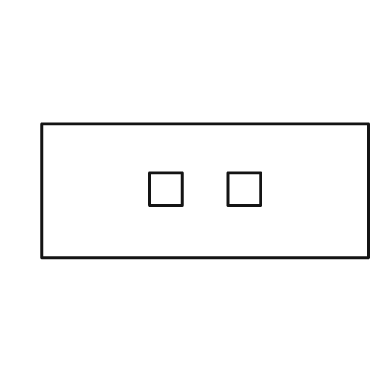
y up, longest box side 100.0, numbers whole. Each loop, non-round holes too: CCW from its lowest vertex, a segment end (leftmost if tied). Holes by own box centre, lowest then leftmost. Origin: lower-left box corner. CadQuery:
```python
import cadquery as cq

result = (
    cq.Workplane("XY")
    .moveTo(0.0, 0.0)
    .lineTo(100.0, 0.0)
    .lineTo(100.0, 41.0)
    .lineTo(0.0, 41.0)
    .close()
    .moveTo(33.0, 16.0)
    .lineTo(43.0, 16.0)
    .lineTo(43.0, 26.0)
    .lineTo(33.0, 26.0)
    .close()
    .moveTo(57.0, 16.0)
    .lineTo(67.0, 16.0)
    .lineTo(67.0, 26.0)
    .lineTo(57.0, 26.0)
    .close()
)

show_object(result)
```